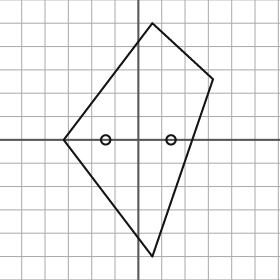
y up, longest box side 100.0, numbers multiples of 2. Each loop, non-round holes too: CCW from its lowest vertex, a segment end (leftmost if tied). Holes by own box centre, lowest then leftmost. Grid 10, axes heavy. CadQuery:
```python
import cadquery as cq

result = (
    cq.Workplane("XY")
    .moveTo(6.0, -50.0)
    .lineTo(32.0, 26.0)
    .lineTo(6.0, 50.0)
    .lineTo(-32.0, 0.0)
    .close()
    .moveTo(-14.0, 0.0)
    .circle(2.0)
    .moveTo(14.0, 0.0)
    .circle(2.0)
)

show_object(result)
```